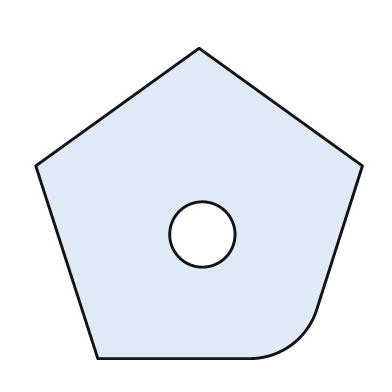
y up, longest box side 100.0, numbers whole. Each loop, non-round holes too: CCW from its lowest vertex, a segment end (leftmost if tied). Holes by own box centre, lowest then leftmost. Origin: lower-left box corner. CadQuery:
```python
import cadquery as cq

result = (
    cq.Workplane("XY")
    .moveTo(19.0, 0.0)
    .lineTo(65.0, 0.0)
    .threePointArc((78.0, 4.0), (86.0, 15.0))
    .lineTo(100.0, 59.0)
    .lineTo(50.0, 95.0)
    .lineTo(0.0, 59.0)
    .close()
    .moveTo(51.0, 38.0)
    .circle(10.0)
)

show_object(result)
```